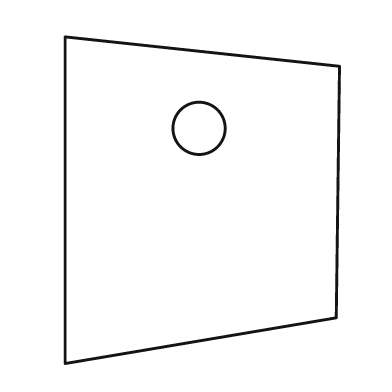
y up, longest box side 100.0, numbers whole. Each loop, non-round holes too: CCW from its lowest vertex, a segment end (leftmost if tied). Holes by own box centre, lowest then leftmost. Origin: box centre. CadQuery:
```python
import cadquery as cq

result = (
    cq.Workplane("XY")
    .moveTo(-42.0, -50.0)
    .lineTo(41.0, -36.0)
    .lineTo(42.0, 41.0)
    .lineTo(-42.0, 50.0)
    .close()
    .moveTo(-1.0, 22.0)
    .circle(8.0)
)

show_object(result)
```